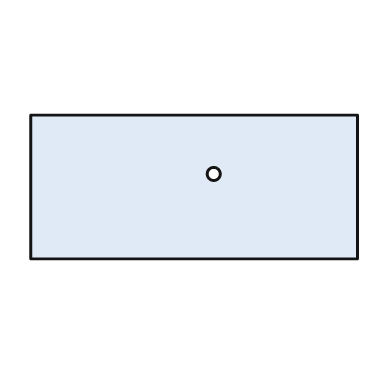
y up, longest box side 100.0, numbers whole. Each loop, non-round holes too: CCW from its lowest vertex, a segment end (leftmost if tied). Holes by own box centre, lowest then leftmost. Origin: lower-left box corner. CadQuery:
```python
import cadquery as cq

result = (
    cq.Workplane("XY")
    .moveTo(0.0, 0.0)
    .lineTo(100.0, 0.0)
    .lineTo(100.0, 44.0)
    .lineTo(0.0, 44.0)
    .close()
    .moveTo(56.0, 26.0)
    .circle(2.0)
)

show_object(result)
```